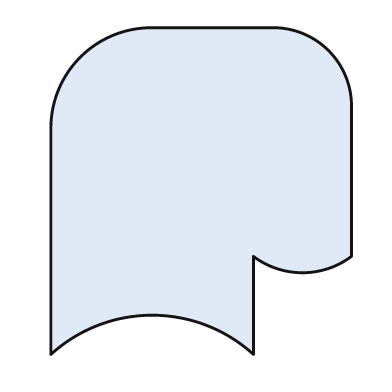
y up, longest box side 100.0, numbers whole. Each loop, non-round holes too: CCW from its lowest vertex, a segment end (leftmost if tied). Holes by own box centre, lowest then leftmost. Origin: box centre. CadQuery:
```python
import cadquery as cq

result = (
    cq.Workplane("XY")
    .moveTo(-46.0, -50.0)
    .threePointArc((-15.0, -38.0), (16.0, -50.0))
    .lineTo(16.0, -20.0)
    .threePointArc((31.0, -25.0), (46.0, -20.0))
    .lineTo(46.0, 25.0)
    .threePointArc((39.0, 43.0), (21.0, 50.0))
    .lineTo(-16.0, 50.0)
    .threePointArc((-37.0, 41.0), (-46.0, 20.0))
    .close()
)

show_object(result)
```